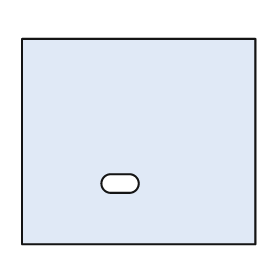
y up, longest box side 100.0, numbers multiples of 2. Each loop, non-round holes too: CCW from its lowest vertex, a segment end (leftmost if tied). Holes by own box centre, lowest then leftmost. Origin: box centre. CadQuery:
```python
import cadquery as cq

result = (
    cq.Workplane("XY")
    .moveTo(-50.0, -44.0)
    .lineTo(50.0, -44.0)
    .lineTo(50.0, 44.0)
    .lineTo(-50.0, 44.0)
    .close()
    .moveTo(-12.0, -22.0)
    .lineTo(-4.0, -22.0)
    .threePointArc((0.0, -18.0), (-4.0, -14.0))
    .lineTo(-12.0, -14.0)
    .threePointArc((-16.0, -18.0), (-12.0, -22.0))
    .close()
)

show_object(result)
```